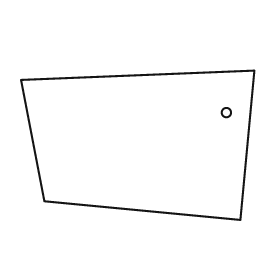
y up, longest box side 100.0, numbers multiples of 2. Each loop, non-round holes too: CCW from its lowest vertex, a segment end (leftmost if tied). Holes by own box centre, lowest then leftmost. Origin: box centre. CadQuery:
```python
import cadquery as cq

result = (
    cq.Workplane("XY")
    .moveTo(44.0, -32.0)
    .lineTo(50.0, 32.0)
    .lineTo(-50.0, 28.0)
    .lineTo(-40.0, -24.0)
    .close()
    .moveTo(38.0, 14.0)
    .circle(2.0)
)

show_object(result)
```